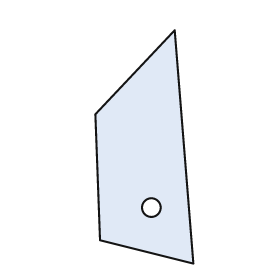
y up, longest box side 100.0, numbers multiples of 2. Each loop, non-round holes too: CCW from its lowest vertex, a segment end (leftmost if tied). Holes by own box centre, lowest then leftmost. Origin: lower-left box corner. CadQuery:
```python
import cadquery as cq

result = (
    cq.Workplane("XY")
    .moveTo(42.0, 0.0)
    .lineTo(34.0, 100.0)
    .lineTo(0.0, 64.0)
    .lineTo(2.0, 10.0)
    .close()
    .moveTo(24.0, 24.0)
    .circle(4.0)
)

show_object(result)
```